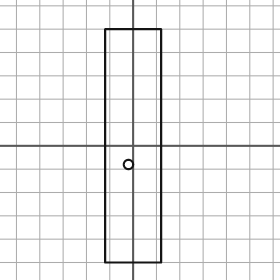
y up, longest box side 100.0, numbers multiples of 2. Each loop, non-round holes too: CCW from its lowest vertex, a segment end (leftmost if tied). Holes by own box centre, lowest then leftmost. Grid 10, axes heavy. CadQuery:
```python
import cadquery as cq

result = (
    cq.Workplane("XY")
    .moveTo(-12.0, -50.0)
    .lineTo(12.0, -50.0)
    .lineTo(12.0, 50.0)
    .lineTo(-12.0, 50.0)
    .close()
    .moveTo(-2.0, -8.0)
    .circle(2.0)
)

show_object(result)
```